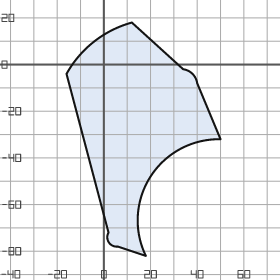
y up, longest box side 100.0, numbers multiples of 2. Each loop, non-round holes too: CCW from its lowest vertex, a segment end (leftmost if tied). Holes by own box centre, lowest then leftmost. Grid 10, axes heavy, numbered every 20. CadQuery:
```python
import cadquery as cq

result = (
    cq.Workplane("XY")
    .moveTo(18.0, -82.0)
    .threePointArc((20.0, -48.0), (50.0, -32.0))
    .lineTo(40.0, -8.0)
    .threePointArc((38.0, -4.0), (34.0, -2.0))
    .lineTo(12.0, 18.0)
    .threePointArc((-4.0, 10.0), (-16.0, -4.0))
    .lineTo(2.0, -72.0)
    .threePointArc((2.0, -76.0), (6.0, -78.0))
    .close()
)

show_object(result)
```